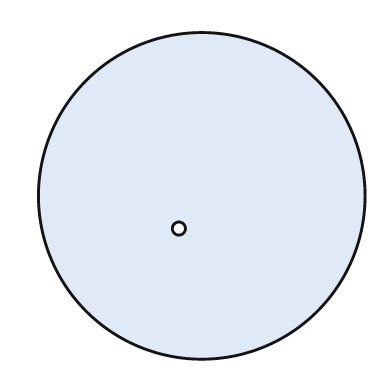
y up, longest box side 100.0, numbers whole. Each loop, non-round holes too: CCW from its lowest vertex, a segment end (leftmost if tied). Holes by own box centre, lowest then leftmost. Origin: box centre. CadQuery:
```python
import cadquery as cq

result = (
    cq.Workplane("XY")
    .moveTo(0.0, 0.0)
    .circle(50.0)
    .moveTo(-7.0, -10.0)
    .circle(2.0)
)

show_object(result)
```